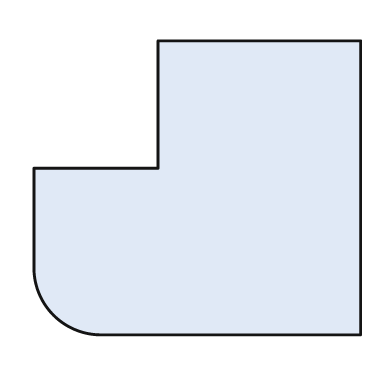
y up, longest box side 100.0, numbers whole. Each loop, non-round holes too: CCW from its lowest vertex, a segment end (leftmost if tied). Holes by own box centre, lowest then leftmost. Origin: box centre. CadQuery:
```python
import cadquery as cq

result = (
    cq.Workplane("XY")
    .moveTo(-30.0, -45.0)
    .lineTo(50.0, -45.0)
    .lineTo(50.0, 45.0)
    .lineTo(-12.0, 45.0)
    .lineTo(-12.0, 6.0)
    .lineTo(-50.0, 6.0)
    .lineTo(-50.0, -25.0)
    .threePointArc((-44.0, -39.0), (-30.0, -45.0))
    .close()
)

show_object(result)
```